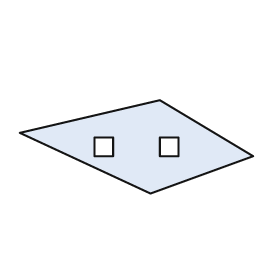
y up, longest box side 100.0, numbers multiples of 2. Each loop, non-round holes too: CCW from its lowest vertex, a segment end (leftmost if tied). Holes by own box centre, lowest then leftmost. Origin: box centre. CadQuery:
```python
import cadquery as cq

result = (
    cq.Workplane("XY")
    .moveTo(6.0, -20.0)
    .lineTo(50.0, -4.0)
    .lineTo(10.0, 20.0)
    .lineTo(-50.0, 6.0)
    .close()
    .moveTo(-18.0, -4.0)
    .lineTo(-10.0, -4.0)
    .lineTo(-10.0, 4.0)
    .lineTo(-18.0, 4.0)
    .close()
    .moveTo(10.0, -4.0)
    .lineTo(18.0, -4.0)
    .lineTo(18.0, 4.0)
    .lineTo(10.0, 4.0)
    .close()
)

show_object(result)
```